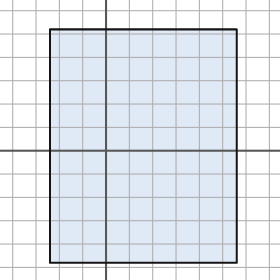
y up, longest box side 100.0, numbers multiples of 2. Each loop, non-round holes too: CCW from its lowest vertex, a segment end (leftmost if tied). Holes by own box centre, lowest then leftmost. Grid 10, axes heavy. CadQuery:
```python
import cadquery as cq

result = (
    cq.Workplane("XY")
    .moveTo(-24.0, -48.0)
    .lineTo(56.0, -48.0)
    .lineTo(56.0, 52.0)
    .lineTo(-24.0, 52.0)
    .close()
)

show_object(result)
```